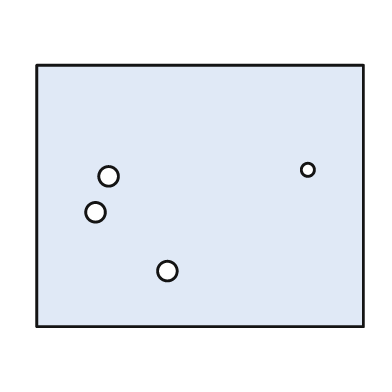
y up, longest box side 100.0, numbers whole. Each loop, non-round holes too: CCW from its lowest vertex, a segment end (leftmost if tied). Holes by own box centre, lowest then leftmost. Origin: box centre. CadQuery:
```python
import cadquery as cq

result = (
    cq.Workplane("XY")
    .moveTo(-50.0, -40.0)
    .lineTo(50.0, -40.0)
    .lineTo(50.0, 40.0)
    .lineTo(-50.0, 40.0)
    .close()
    .moveTo(-10.0, -23.0)
    .circle(3.0)
    .moveTo(-32.0, -5.0)
    .circle(3.0)
    .moveTo(-28.0, 6.0)
    .circle(3.0)
    .moveTo(33.0, 8.0)
    .circle(2.0)
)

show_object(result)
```